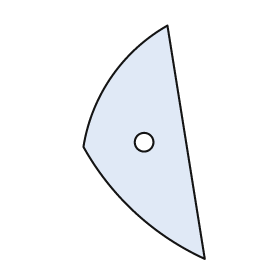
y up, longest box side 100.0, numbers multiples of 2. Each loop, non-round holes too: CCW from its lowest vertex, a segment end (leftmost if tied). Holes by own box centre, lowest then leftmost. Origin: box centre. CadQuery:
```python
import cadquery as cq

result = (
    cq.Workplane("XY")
    .moveTo(26.0, -50.0)
    .lineTo(10.0, 50.0)
    .threePointArc((-14.0, 28.0), (-26.0, -2.0))
    .threePointArc((-4.0, -30.0), (26.0, -50.0))
    .close()
    .moveTo(0.0, 0.0)
    .circle(4.0)
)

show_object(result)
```